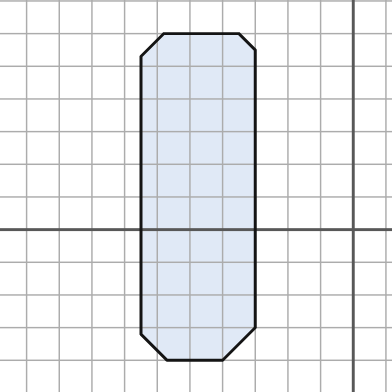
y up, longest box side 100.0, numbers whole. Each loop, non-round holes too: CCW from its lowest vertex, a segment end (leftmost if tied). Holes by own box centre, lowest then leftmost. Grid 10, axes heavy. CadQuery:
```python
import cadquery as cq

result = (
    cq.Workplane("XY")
    .moveTo(-57.0, -40.0)
    .lineTo(-40.0, -40.0)
    .lineTo(-30.0, -30.0)
    .lineTo(-30.0, 55.0)
    .lineTo(-35.0, 60.0)
    .lineTo(-58.0, 60.0)
    .lineTo(-65.0, 53.0)
    .lineTo(-65.0, -32.0)
    .close()
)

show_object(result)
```